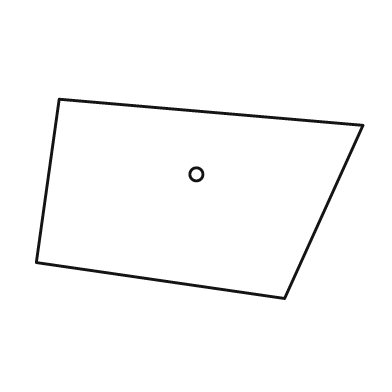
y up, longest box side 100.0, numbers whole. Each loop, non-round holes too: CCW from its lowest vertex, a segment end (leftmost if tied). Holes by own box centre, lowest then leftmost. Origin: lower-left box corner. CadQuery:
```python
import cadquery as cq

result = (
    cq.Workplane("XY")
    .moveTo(76.0, 0.0)
    .lineTo(100.0, 53.0)
    .lineTo(7.0, 61.0)
    .lineTo(0.0, 11.0)
    .close()
    .moveTo(49.0, 38.0)
    .circle(2.0)
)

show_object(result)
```